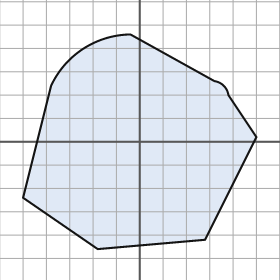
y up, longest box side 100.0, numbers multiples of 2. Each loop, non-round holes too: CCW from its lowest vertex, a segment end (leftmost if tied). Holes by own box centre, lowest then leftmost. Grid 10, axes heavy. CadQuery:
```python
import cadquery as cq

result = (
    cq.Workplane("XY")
    .moveTo(-18.0, -46.0)
    .lineTo(28.0, -42.0)
    .lineTo(50.0, 2.0)
    .lineTo(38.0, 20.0)
    .threePointArc((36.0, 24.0), (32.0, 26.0))
    .lineTo(-4.0, 46.0)
    .threePointArc((-24.0, 40.0), (-38.0, 24.0))
    .lineTo(-50.0, -24.0)
    .close()
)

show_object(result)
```